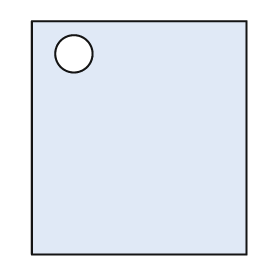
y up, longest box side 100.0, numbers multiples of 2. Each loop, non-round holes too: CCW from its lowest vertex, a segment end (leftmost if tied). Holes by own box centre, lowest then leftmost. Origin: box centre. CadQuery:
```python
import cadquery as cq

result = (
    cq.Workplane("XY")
    .moveTo(-46.0, -50.0)
    .lineTo(46.0, -50.0)
    .lineTo(46.0, 50.0)
    .lineTo(-46.0, 50.0)
    .close()
    .moveTo(-28.0, 36.0)
    .circle(8.0)
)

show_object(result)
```